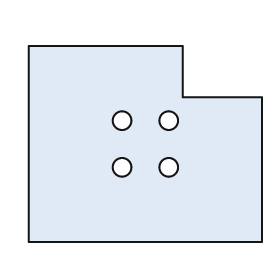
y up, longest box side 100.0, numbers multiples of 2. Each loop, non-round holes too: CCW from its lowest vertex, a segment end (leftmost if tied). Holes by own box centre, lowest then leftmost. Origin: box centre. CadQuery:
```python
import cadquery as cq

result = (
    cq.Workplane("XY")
    .moveTo(-50.0, -42.0)
    .lineTo(50.0, -42.0)
    .lineTo(50.0, 20.0)
    .lineTo(16.0, 20.0)
    .lineTo(16.0, 42.0)
    .lineTo(-50.0, 42.0)
    .close()
    .moveTo(-10.0, -10.0)
    .circle(4.0)
    .moveTo(10.0, -10.0)
    .circle(4.0)
    .moveTo(-10.0, 10.0)
    .circle(4.0)
    .moveTo(10.0, 10.0)
    .circle(4.0)
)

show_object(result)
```